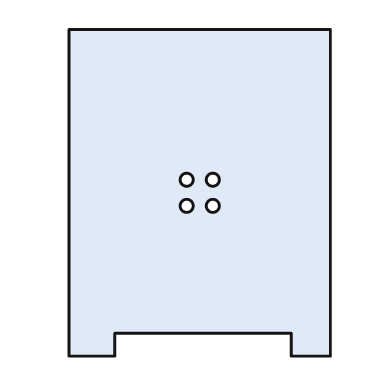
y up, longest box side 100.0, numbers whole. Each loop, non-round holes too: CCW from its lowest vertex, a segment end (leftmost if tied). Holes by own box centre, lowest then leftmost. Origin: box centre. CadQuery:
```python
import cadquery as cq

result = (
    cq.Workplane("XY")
    .moveTo(-40.0, -50.0)
    .lineTo(-26.0, -50.0)
    .lineTo(-26.0, -43.0)
    .lineTo(28.0, -43.0)
    .lineTo(28.0, -50.0)
    .lineTo(40.0, -50.0)
    .lineTo(40.0, 50.0)
    .lineTo(-40.0, 50.0)
    .close()
    .moveTo(-4.0, -4.0)
    .circle(2.0)
    .moveTo(4.0, -4.0)
    .circle(2.0)
    .moveTo(-4.0, 4.0)
    .circle(2.0)
    .moveTo(4.0, 4.0)
    .circle(2.0)
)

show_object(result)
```